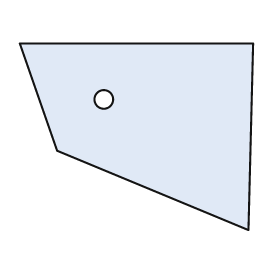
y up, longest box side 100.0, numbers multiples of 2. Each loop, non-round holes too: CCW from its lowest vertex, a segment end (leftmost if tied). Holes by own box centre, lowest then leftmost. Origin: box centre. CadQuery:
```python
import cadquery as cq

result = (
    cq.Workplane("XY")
    .moveTo(48.0, -40.0)
    .lineTo(50.0, 40.0)
    .lineTo(-50.0, 40.0)
    .lineTo(-34.0, -6.0)
    .close()
    .moveTo(-14.0, 16.0)
    .circle(4.0)
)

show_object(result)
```